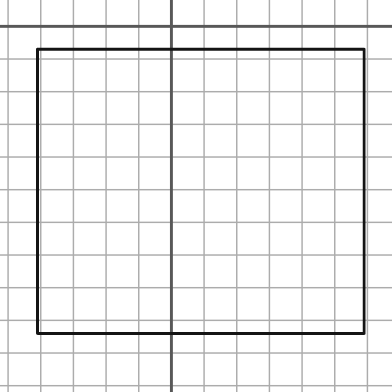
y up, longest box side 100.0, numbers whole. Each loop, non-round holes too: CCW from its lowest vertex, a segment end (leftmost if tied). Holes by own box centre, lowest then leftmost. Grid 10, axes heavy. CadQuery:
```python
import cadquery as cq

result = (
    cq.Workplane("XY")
    .moveTo(-41.0, -94.0)
    .lineTo(59.0, -94.0)
    .lineTo(59.0, -7.0)
    .lineTo(-41.0, -7.0)
    .close()
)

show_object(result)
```